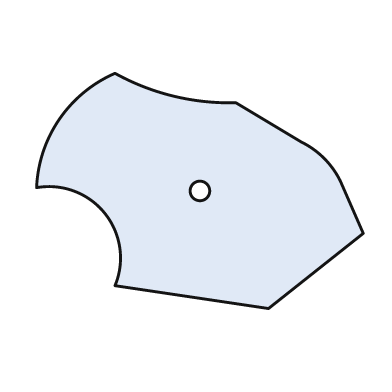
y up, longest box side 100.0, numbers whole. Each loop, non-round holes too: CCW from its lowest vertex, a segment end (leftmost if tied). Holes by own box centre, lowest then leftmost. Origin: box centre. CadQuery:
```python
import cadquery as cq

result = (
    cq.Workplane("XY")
    .moveTo(21.0, -36.0)
    .lineTo(50.0, -13.0)
    .lineTo(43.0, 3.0)
    .threePointArc((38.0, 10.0), (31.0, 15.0))
    .lineTo(11.0, 27.0)
    .threePointArc((-8.0, 29.0), (-26.0, 36.0))
    .threePointArc((-43.0, 22.0), (-50.0, 1.0))
    .threePointArc((-29.0, -7.0), (-26.0, -29.0))
    .close()
    .moveTo(0.0, 0.0)
    .circle(3.0)
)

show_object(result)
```